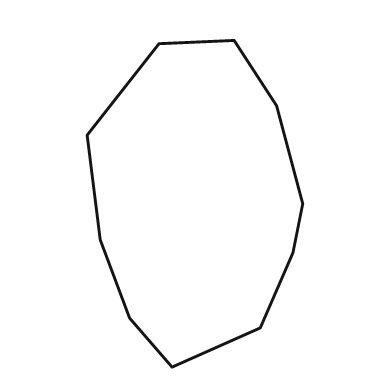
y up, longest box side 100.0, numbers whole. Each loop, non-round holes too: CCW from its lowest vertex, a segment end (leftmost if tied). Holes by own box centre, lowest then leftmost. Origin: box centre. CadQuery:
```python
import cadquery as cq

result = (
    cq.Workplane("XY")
    .moveTo(-7.0, -50.0)
    .lineTo(20.0, -38.0)
    .lineTo(30.0, -15.0)
    .lineTo(33.0, 0.0)
    .lineTo(25.0, 30.0)
    .lineTo(12.0, 50.0)
    .lineTo(-11.0, 49.0)
    .lineTo(-33.0, 21.0)
    .lineTo(-29.0, -11.0)
    .lineTo(-20.0, -35.0)
    .close()
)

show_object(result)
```